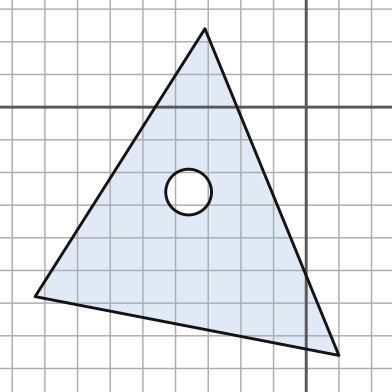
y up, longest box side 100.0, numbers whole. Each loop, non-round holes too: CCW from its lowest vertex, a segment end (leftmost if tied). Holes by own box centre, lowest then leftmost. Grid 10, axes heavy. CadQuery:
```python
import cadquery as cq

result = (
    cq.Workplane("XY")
    .moveTo(10.0, -76.0)
    .lineTo(-31.0, 24.0)
    .lineTo(-83.0, -58.0)
    .close()
    .moveTo(-36.0, -26.0)
    .circle(7.0)
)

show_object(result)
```